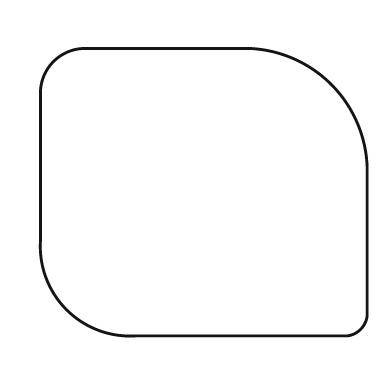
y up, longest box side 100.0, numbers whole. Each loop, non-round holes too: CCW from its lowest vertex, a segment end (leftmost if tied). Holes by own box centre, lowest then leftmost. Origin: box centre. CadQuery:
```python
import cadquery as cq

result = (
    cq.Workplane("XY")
    .moveTo(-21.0, -44.0)
    .lineTo(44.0, -44.0)
    .threePointArc((48.0, -42.0), (50.0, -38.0))
    .lineTo(50.0, 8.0)
    .threePointArc((39.0, 33.0), (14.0, 44.0))
    .lineTo(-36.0, 44.0)
    .threePointArc((-46.0, 40.0), (-50.0, 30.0))
    .lineTo(-50.0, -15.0)
    .threePointArc((-42.0, -36.0), (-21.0, -44.0))
    .close()
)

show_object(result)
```